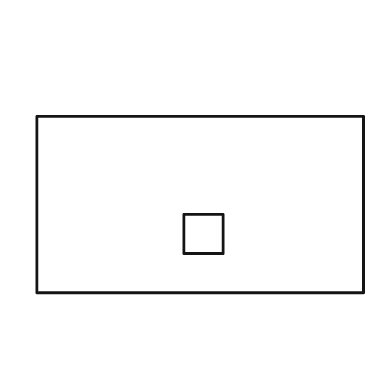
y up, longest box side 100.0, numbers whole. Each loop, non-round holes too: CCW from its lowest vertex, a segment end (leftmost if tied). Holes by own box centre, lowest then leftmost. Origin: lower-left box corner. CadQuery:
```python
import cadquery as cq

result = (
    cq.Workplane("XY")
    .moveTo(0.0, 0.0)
    .lineTo(100.0, 0.0)
    .lineTo(100.0, 54.0)
    .lineTo(0.0, 54.0)
    .close()
    .moveTo(45.0, 12.0)
    .lineTo(57.0, 12.0)
    .lineTo(57.0, 24.0)
    .lineTo(45.0, 24.0)
    .close()
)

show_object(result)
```